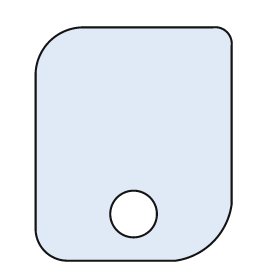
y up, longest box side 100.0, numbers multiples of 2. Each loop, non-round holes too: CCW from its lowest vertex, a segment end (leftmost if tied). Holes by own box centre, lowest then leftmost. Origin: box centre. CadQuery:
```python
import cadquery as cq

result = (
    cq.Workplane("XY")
    .moveTo(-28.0, -50.0)
    .lineTo(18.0, -50.0)
    .threePointArc((34.0, -42.0), (42.0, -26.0))
    .lineTo(42.0, 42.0)
    .threePointArc((40.0, 48.0), (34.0, 50.0))
    .lineTo(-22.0, 50.0)
    .threePointArc((-36.0, 44.0), (-42.0, 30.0))
    .lineTo(-42.0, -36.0)
    .threePointArc((-38.0, -46.0), (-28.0, -50.0))
    .close()
    .moveTo(0.0, -30.0)
    .circle(10.0)
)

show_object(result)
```